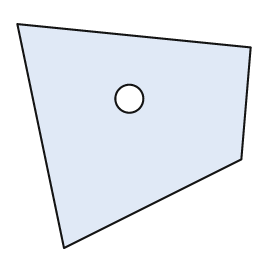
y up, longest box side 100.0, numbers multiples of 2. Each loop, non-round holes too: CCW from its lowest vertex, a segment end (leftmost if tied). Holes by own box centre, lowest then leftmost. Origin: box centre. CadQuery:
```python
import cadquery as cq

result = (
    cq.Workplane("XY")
    .moveTo(-30.0, -48.0)
    .lineTo(46.0, -10.0)
    .lineTo(50.0, 38.0)
    .lineTo(-50.0, 48.0)
    .close()
    .moveTo(-2.0, 16.0)
    .circle(6.0)
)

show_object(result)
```